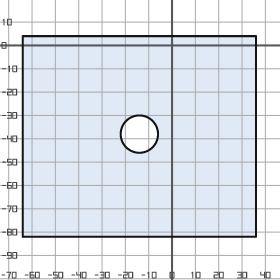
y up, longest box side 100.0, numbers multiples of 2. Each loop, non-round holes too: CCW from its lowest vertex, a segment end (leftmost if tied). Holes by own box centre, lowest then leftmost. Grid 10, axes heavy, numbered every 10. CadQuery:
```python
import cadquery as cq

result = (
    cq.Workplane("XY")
    .moveTo(-64.0, -82.0)
    .lineTo(36.0, -82.0)
    .lineTo(36.0, 4.0)
    .lineTo(-64.0, 4.0)
    .close()
    .moveTo(-14.0, -38.0)
    .circle(8.0)
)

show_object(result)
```